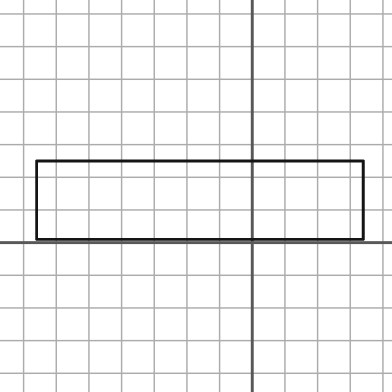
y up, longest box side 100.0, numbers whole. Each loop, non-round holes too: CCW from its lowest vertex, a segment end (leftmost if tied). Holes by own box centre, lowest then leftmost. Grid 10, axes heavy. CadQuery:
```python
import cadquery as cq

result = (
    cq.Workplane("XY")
    .moveTo(-66.0, 1.0)
    .lineTo(34.0, 1.0)
    .lineTo(34.0, 25.0)
    .lineTo(-66.0, 25.0)
    .close()
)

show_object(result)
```